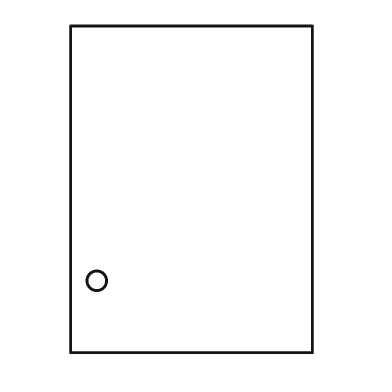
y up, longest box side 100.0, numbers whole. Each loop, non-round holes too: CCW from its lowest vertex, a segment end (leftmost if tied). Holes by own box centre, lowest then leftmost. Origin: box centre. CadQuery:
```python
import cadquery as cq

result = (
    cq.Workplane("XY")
    .moveTo(-37.0, -50.0)
    .lineTo(37.0, -50.0)
    .lineTo(37.0, 50.0)
    .lineTo(-37.0, 50.0)
    .close()
    .moveTo(-29.0, -28.0)
    .circle(3.0)
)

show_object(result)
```